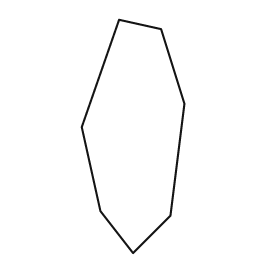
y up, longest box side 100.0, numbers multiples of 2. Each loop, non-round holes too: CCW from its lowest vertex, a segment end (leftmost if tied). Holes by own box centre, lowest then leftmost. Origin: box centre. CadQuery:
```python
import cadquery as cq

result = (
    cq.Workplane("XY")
    .moveTo(0.0, -50.0)
    .lineTo(16.0, -34.0)
    .lineTo(22.0, 14.0)
    .lineTo(12.0, 46.0)
    .lineTo(-6.0, 50.0)
    .lineTo(-22.0, 4.0)
    .lineTo(-14.0, -32.0)
    .close()
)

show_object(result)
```